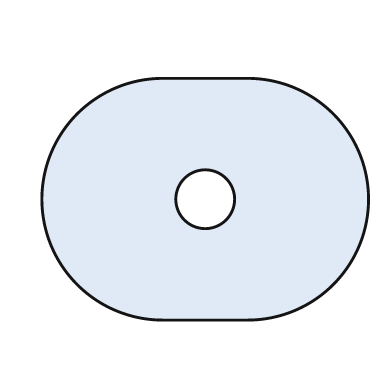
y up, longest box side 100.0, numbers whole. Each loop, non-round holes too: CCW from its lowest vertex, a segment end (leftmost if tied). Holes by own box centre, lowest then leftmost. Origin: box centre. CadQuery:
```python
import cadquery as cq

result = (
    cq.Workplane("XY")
    .moveTo(-13.0, -37.0)
    .lineTo(13.0, -37.0)
    .threePointArc((50.0, 0.0), (13.0, 37.0))
    .lineTo(-13.0, 37.0)
    .threePointArc((-50.0, 0.0), (-13.0, -37.0))
    .close()
    .moveTo(0.0, 0.0)
    .circle(9.0)
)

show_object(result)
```